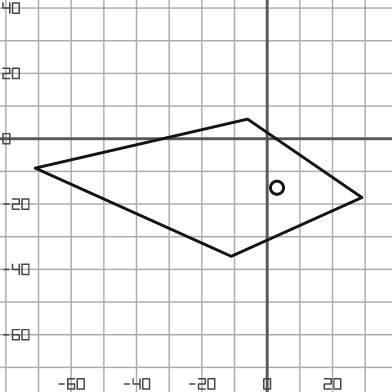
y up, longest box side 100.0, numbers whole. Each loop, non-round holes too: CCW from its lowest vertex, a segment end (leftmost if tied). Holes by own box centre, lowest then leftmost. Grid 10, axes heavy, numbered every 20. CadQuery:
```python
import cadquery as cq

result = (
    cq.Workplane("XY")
    .moveTo(-11.0, -36.0)
    .lineTo(29.0, -18.0)
    .lineTo(-6.0, 6.0)
    .lineTo(-71.0, -9.0)
    .close()
    .moveTo(3.0, -15.0)
    .circle(2.0)
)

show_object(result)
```